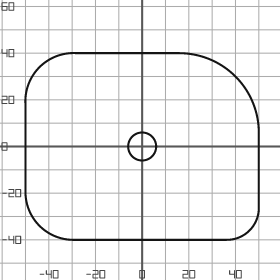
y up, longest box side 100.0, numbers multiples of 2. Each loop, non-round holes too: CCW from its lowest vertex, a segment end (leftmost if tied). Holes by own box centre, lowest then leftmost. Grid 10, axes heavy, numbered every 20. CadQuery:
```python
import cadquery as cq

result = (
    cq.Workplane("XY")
    .moveTo(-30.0, -40.0)
    .lineTo(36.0, -40.0)
    .threePointArc((46.0, -36.0), (50.0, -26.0))
    .lineTo(50.0, 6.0)
    .threePointArc((40.0, 30.0), (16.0, 40.0))
    .lineTo(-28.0, 40.0)
    .threePointArc((-44.0, 34.0), (-50.0, 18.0))
    .lineTo(-50.0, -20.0)
    .threePointArc((-44.0, -34.0), (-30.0, -40.0))
    .close()
    .moveTo(0.0, 0.0)
    .circle(6.0)
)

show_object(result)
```